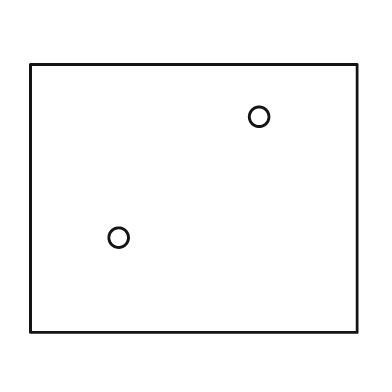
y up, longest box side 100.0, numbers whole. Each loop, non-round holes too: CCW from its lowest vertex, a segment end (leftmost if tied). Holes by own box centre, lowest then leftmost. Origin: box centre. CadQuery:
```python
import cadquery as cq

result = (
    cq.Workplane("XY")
    .moveTo(-50.0, -41.0)
    .lineTo(50.0, -41.0)
    .lineTo(50.0, 41.0)
    .lineTo(-50.0, 41.0)
    .close()
    .moveTo(-23.0, -12.0)
    .circle(3.0)
    .moveTo(20.0, 25.0)
    .circle(3.0)
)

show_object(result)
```